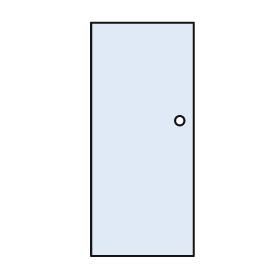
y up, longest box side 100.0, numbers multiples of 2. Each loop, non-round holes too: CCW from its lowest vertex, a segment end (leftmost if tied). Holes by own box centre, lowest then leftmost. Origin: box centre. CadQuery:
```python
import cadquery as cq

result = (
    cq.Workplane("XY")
    .moveTo(-22.0, -50.0)
    .lineTo(22.0, -50.0)
    .lineTo(22.0, 50.0)
    .lineTo(-22.0, 50.0)
    .close()
    .moveTo(16.0, 8.0)
    .circle(2.0)
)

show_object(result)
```